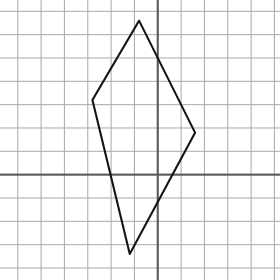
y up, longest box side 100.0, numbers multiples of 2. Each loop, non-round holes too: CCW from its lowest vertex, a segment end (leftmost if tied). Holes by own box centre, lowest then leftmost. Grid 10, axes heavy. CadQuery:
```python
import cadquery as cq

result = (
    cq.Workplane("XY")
    .moveTo(-12.0, -34.0)
    .lineTo(16.0, 18.0)
    .lineTo(-8.0, 66.0)
    .lineTo(-28.0, 32.0)
    .close()
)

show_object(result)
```